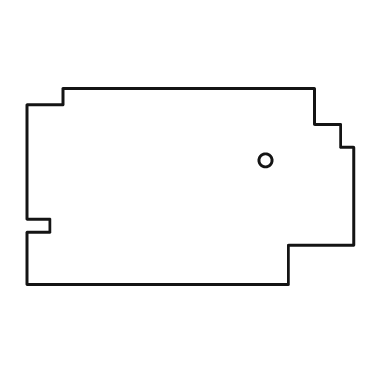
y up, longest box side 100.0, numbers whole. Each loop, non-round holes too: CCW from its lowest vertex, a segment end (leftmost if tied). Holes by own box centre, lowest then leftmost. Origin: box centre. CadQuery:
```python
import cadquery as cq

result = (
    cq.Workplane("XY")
    .moveTo(-50.0, -30.0)
    .lineTo(30.0, -30.0)
    .lineTo(30.0, -18.0)
    .lineTo(50.0, -18.0)
    .lineTo(50.0, 12.0)
    .lineTo(46.0, 12.0)
    .lineTo(46.0, 19.0)
    .lineTo(38.0, 19.0)
    .lineTo(38.0, 30.0)
    .lineTo(-39.0, 30.0)
    .lineTo(-39.0, 25.0)
    .lineTo(-50.0, 25.0)
    .lineTo(-50.0, -10.0)
    .lineTo(-43.0, -10.0)
    .lineTo(-43.0, -14.0)
    .lineTo(-50.0, -14.0)
    .close()
    .moveTo(23.0, 8.0)
    .circle(2.0)
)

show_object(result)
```